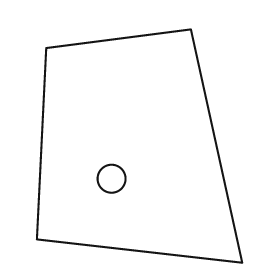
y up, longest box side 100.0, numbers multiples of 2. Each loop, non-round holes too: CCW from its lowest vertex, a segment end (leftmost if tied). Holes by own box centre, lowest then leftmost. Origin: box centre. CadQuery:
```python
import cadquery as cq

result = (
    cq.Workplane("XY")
    .moveTo(44.0, -50.0)
    .lineTo(22.0, 50.0)
    .lineTo(-40.0, 42.0)
    .lineTo(-44.0, -40.0)
    .close()
    .moveTo(-12.0, -14.0)
    .circle(6.0)
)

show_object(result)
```